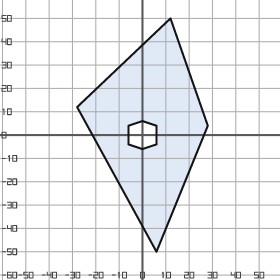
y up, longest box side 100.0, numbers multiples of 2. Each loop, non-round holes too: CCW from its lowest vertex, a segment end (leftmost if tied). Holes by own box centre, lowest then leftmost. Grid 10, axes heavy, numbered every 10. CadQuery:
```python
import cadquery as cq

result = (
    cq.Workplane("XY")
    .moveTo(6.0, -50.0)
    .lineTo(28.0, 4.0)
    .lineTo(12.0, 50.0)
    .lineTo(-28.0, 12.0)
    .close()
    .moveTo(0.0, -6.0)
    .lineTo(6.0, -4.0)
    .lineTo(6.0, 4.0)
    .lineTo(0.0, 6.0)
    .lineTo(-6.0, 4.0)
    .lineTo(-6.0, -4.0)
    .close()
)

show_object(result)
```